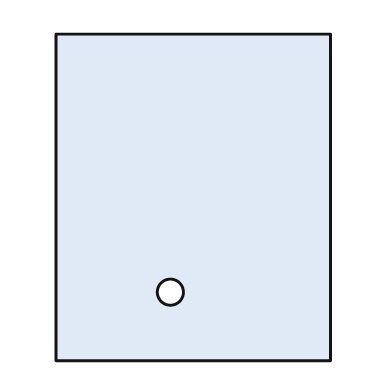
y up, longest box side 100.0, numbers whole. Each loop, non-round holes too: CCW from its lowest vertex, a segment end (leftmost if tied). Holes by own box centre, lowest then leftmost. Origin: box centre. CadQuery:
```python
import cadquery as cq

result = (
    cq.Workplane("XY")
    .moveTo(-42.0, -50.0)
    .lineTo(42.0, -50.0)
    .lineTo(42.0, 50.0)
    .lineTo(-42.0, 50.0)
    .close()
    .moveTo(-7.0, -29.0)
    .circle(4.0)
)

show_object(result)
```